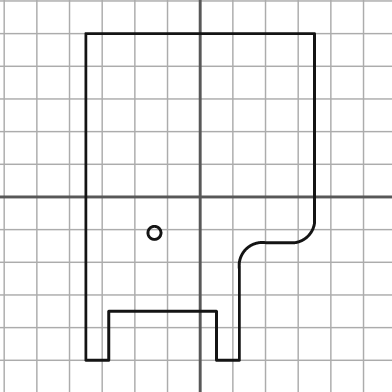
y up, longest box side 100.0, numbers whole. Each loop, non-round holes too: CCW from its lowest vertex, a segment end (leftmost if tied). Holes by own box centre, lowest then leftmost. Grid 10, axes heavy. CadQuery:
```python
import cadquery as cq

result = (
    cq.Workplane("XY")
    .moveTo(-35.0, -50.0)
    .lineTo(-28.0, -50.0)
    .lineTo(-28.0, -35.0)
    .lineTo(5.0, -35.0)
    .lineTo(5.0, -50.0)
    .lineTo(12.0, -50.0)
    .lineTo(12.0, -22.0)
    .threePointArc((14.0, -16.0), (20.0, -14.0))
    .lineTo(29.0, -14.0)
    .threePointArc((33.0, -12.0), (35.0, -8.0))
    .lineTo(35.0, 50.0)
    .lineTo(-35.0, 50.0)
    .close()
    .moveTo(-14.0, -11.0)
    .circle(2.0)
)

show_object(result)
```